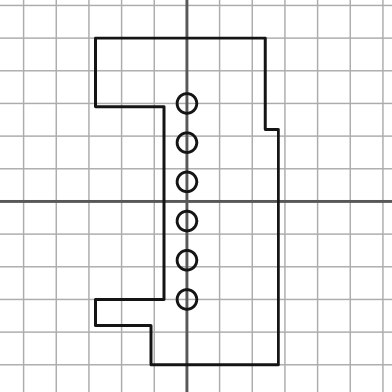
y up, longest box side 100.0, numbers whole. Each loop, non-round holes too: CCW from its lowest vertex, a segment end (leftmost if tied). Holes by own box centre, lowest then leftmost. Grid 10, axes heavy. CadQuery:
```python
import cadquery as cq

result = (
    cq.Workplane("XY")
    .moveTo(-11.0, -50.0)
    .lineTo(28.0, -50.0)
    .lineTo(28.0, 22.0)
    .lineTo(24.0, 22.0)
    .lineTo(24.0, 50.0)
    .lineTo(-28.0, 50.0)
    .lineTo(-28.0, 29.0)
    .lineTo(-7.0, 29.0)
    .lineTo(-7.0, -30.0)
    .lineTo(-28.0, -30.0)
    .lineTo(-28.0, -38.0)
    .lineTo(-11.0, -38.0)
    .close()
    .moveTo(0.0, -30.0)
    .circle(3.0)
    .moveTo(0.0, -18.0)
    .circle(3.0)
    .moveTo(0.0, -6.0)
    .circle(3.0)
    .moveTo(0.0, 6.0)
    .circle(3.0)
    .moveTo(0.0, 18.0)
    .circle(3.0)
    .moveTo(0.0, 30.0)
    .circle(3.0)
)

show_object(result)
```